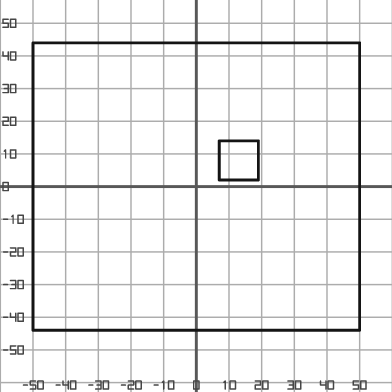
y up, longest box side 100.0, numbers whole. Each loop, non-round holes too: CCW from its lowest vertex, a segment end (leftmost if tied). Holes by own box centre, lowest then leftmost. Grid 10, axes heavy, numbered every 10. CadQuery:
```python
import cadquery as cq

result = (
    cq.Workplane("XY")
    .moveTo(-50.0, -44.0)
    .lineTo(50.0, -44.0)
    .lineTo(50.0, 44.0)
    .lineTo(-50.0, 44.0)
    .close()
    .moveTo(7.0, 2.0)
    .lineTo(19.0, 2.0)
    .lineTo(19.0, 14.0)
    .lineTo(7.0, 14.0)
    .close()
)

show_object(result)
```